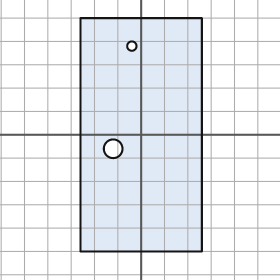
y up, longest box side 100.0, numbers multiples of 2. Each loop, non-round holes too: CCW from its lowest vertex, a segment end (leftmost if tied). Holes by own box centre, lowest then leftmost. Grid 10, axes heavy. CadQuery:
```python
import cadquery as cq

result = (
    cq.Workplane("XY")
    .moveTo(-26.0, -50.0)
    .lineTo(26.0, -50.0)
    .lineTo(26.0, 50.0)
    .lineTo(-26.0, 50.0)
    .close()
    .moveTo(-12.0, -6.0)
    .circle(4.0)
    .moveTo(-4.0, 38.0)
    .circle(2.0)
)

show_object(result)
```